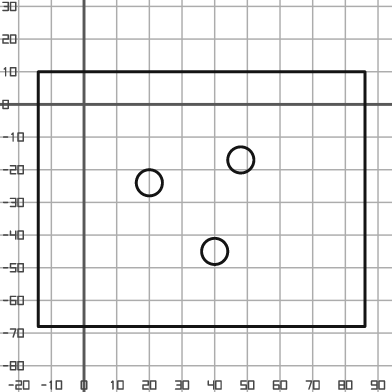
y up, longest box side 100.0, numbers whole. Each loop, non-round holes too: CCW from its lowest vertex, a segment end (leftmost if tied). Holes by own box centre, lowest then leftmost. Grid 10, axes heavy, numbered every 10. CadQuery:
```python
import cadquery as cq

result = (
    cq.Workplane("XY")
    .moveTo(-14.0, -68.0)
    .lineTo(86.0, -68.0)
    .lineTo(86.0, 10.0)
    .lineTo(-14.0, 10.0)
    .close()
    .moveTo(40.0, -45.0)
    .circle(4.0)
    .moveTo(20.0, -24.0)
    .circle(4.0)
    .moveTo(48.0, -17.0)
    .circle(4.0)
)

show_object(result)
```